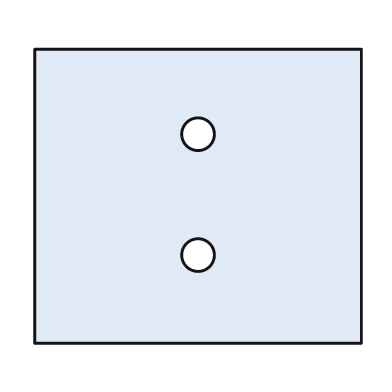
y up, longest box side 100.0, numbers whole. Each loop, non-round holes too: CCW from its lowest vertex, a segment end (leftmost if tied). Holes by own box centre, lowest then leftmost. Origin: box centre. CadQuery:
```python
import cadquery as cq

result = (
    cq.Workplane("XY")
    .moveTo(-50.0, -45.0)
    .lineTo(50.0, -45.0)
    .lineTo(50.0, 45.0)
    .lineTo(-50.0, 45.0)
    .close()
    .moveTo(0.0, -18.0)
    .circle(5.0)
    .moveTo(0.0, 19.0)
    .circle(5.0)
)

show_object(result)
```